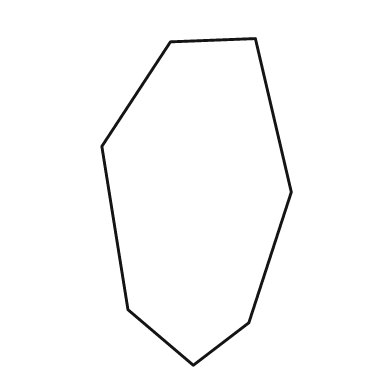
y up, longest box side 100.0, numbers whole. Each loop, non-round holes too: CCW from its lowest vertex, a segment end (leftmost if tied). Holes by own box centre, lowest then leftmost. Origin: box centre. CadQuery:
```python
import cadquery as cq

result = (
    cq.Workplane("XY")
    .moveTo(-1.0, -50.0)
    .lineTo(16.0, -37.0)
    .lineTo(29.0, 3.0)
    .lineTo(18.0, 50.0)
    .lineTo(-8.0, 49.0)
    .lineTo(-29.0, 17.0)
    .lineTo(-21.0, -33.0)
    .close()
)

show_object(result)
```